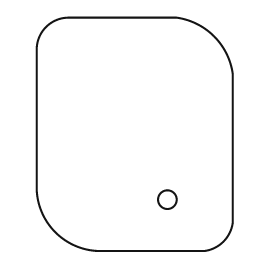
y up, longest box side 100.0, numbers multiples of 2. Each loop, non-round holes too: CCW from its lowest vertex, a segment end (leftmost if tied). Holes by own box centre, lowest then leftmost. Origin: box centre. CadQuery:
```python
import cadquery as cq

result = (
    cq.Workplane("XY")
    .moveTo(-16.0, -50.0)
    .lineTo(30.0, -50.0)
    .threePointArc((38.0, -46.0), (42.0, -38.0))
    .lineTo(42.0, 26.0)
    .threePointArc((34.0, 42.0), (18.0, 50.0))
    .lineTo(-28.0, 50.0)
    .threePointArc((-38.0, 46.0), (-42.0, 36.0))
    .lineTo(-42.0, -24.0)
    .threePointArc((-34.0, -42.0), (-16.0, -50.0))
    .close()
    .moveTo(14.0, -28.0)
    .circle(4.0)
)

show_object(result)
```